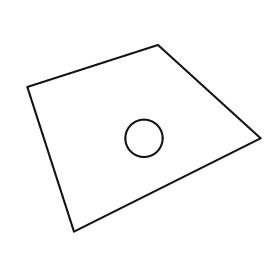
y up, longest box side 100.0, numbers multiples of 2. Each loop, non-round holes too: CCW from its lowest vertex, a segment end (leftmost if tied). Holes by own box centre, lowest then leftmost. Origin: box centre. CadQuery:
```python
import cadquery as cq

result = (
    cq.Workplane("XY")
    .moveTo(-30.0, -40.0)
    .lineTo(50.0, 0.0)
    .lineTo(6.0, 40.0)
    .lineTo(-50.0, 22.0)
    .close()
    .moveTo(0.0, 0.0)
    .circle(8.0)
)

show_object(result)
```